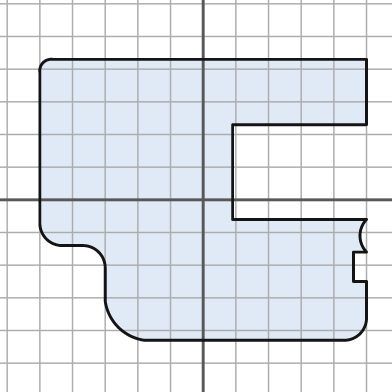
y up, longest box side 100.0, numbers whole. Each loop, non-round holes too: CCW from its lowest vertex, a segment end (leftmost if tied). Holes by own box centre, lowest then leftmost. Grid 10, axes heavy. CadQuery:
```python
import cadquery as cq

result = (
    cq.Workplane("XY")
    .moveTo(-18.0, -43.0)
    .lineTo(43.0, -43.0)
    .threePointArc((48.0, -41.0), (50.0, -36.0))
    .lineTo(50.0, -25.0)
    .lineTo(46.0, -25.0)
    .lineTo(46.0, -16.0)
    .lineTo(50.0, -16.0)
    .threePointArc((48.0, -11.0), (50.0, -6.0))
    .lineTo(9.0, -6.0)
    .lineTo(9.0, 23.0)
    .lineTo(50.0, 23.0)
    .lineTo(50.0, 43.0)
    .lineTo(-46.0, 43.0)
    .threePointArc((-49.0, 42.0), (-50.0, 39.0))
    .lineTo(-50.0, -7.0)
    .threePointArc((-48.0, -12.0), (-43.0, -14.0))
    .lineTo(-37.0, -14.0)
    .threePointArc((-32.0, -16.0), (-30.0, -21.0))
    .lineTo(-30.0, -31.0)
    .threePointArc((-26.0, -39.0), (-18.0, -43.0))
    .close()
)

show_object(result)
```